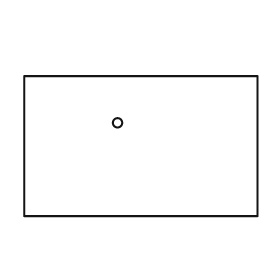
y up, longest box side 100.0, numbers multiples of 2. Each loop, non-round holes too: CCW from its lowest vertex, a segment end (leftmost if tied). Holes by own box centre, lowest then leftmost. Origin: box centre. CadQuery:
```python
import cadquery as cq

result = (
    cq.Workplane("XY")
    .moveTo(-50.0, -30.0)
    .lineTo(50.0, -30.0)
    .lineTo(50.0, 30.0)
    .lineTo(-50.0, 30.0)
    .close()
    .moveTo(-10.0, 10.0)
    .circle(2.0)
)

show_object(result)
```